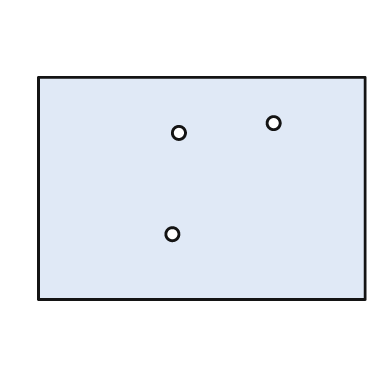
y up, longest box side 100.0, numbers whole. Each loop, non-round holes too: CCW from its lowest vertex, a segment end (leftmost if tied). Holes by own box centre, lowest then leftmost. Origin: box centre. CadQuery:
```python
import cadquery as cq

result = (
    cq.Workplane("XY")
    .moveTo(-50.0, -34.0)
    .lineTo(50.0, -34.0)
    .lineTo(50.0, 34.0)
    .lineTo(-50.0, 34.0)
    .close()
    .moveTo(-9.0, -14.0)
    .circle(2.0)
    .moveTo(-7.0, 17.0)
    .circle(2.0)
    .moveTo(22.0, 20.0)
    .circle(2.0)
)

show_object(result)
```